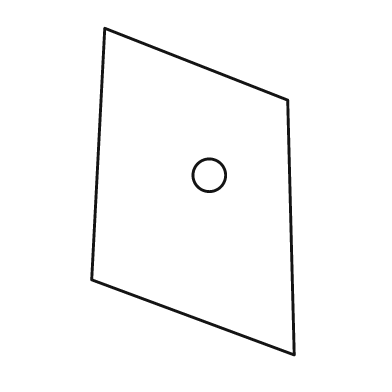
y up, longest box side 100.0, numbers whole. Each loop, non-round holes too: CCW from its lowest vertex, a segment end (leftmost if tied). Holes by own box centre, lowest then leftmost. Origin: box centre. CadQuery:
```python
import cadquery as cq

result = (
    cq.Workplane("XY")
    .moveTo(31.0, -50.0)
    .lineTo(29.0, 28.0)
    .lineTo(-27.0, 50.0)
    .lineTo(-31.0, -27.0)
    .close()
    .moveTo(5.0, 5.0)
    .circle(5.0)
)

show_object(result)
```